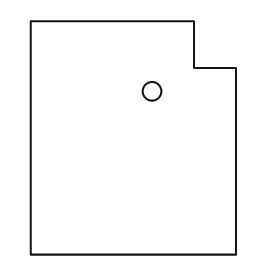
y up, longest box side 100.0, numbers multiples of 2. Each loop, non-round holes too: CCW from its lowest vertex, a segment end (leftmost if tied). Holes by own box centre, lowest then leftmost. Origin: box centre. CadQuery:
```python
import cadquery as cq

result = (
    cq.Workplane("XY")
    .moveTo(-44.0, -50.0)
    .lineTo(44.0, -50.0)
    .lineTo(44.0, 30.0)
    .lineTo(26.0, 30.0)
    .lineTo(26.0, 50.0)
    .lineTo(-44.0, 50.0)
    .close()
    .moveTo(8.0, 20.0)
    .circle(4.0)
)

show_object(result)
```